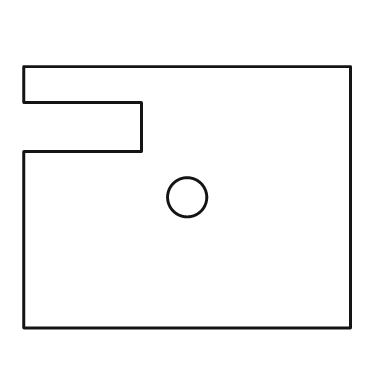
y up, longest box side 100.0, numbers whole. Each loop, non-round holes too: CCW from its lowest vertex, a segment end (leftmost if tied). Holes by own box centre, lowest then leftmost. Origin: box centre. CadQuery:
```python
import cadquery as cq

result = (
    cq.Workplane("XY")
    .moveTo(-50.0, -40.0)
    .lineTo(50.0, -40.0)
    .lineTo(50.0, 40.0)
    .lineTo(-50.0, 40.0)
    .lineTo(-50.0, 29.0)
    .lineTo(-14.0, 29.0)
    .lineTo(-14.0, 14.0)
    .lineTo(-50.0, 14.0)
    .close()
    .moveTo(0.0, 0.0)
    .circle(6.0)
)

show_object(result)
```